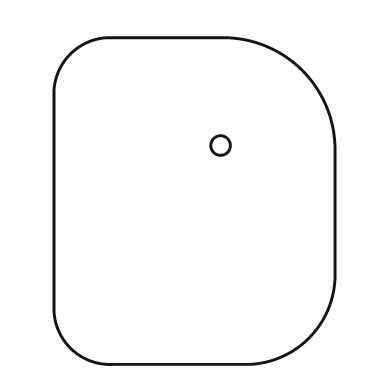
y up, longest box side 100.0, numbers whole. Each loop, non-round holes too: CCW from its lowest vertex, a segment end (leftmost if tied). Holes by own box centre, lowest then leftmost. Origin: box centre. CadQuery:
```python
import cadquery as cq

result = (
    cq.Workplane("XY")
    .moveTo(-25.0, -50.0)
    .lineTo(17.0, -50.0)
    .threePointArc((35.0, -42.0), (43.0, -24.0))
    .lineTo(43.0, 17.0)
    .threePointArc((33.0, 40.0), (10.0, 50.0))
    .lineTo(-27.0, 50.0)
    .threePointArc((-38.0, 45.0), (-43.0, 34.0))
    .lineTo(-43.0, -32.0)
    .threePointArc((-38.0, -45.0), (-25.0, -50.0))
    .close()
    .moveTo(8.0, 17.0)
    .circle(3.0)
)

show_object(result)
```